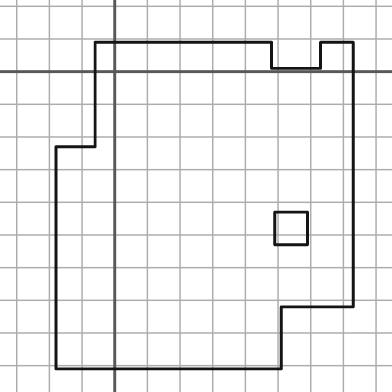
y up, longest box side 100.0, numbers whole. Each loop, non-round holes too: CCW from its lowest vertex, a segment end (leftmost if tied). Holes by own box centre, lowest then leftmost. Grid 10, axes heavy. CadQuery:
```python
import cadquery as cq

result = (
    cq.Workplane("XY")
    .moveTo(-18.0, -91.0)
    .lineTo(51.0, -91.0)
    .lineTo(51.0, -72.0)
    .lineTo(73.0, -72.0)
    .lineTo(73.0, 9.0)
    .lineTo(63.0, 9.0)
    .lineTo(63.0, 1.0)
    .lineTo(48.0, 1.0)
    .lineTo(48.0, 9.0)
    .lineTo(-6.0, 9.0)
    .lineTo(-6.0, -23.0)
    .lineTo(-18.0, -23.0)
    .close()
    .moveTo(49.0, -53.0)
    .lineTo(59.0, -53.0)
    .lineTo(59.0, -43.0)
    .lineTo(49.0, -43.0)
    .close()
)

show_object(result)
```